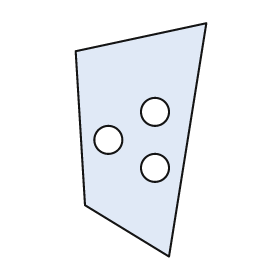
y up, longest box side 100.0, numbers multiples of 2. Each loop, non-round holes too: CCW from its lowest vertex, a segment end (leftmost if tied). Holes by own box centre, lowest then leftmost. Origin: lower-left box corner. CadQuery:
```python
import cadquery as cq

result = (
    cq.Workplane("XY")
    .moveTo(40.0, 0.0)
    .lineTo(56.0, 100.0)
    .lineTo(0.0, 88.0)
    .lineTo(4.0, 22.0)
    .close()
    .moveTo(34.0, 38.0)
    .circle(6.0)
    .moveTo(14.0, 50.0)
    .circle(6.0)
    .moveTo(34.0, 62.0)
    .circle(6.0)
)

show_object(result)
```